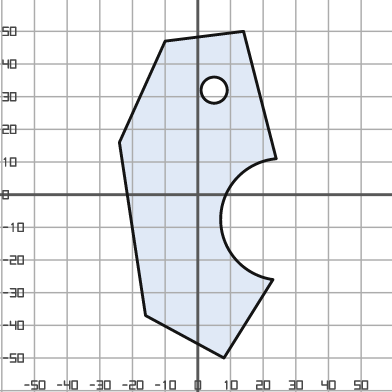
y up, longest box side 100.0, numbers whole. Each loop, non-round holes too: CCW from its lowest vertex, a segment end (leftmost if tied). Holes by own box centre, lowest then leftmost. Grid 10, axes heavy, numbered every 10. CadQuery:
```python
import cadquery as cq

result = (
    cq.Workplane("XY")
    .moveTo(8.0, -50.0)
    .lineTo(23.0, -26.0)
    .threePointArc((7.0, -7.0), (24.0, 11.0))
    .lineTo(14.0, 50.0)
    .lineTo(-10.0, 47.0)
    .lineTo(-24.0, 16.0)
    .lineTo(-16.0, -37.0)
    .close()
    .moveTo(5.0, 32.0)
    .circle(4.0)
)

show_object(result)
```